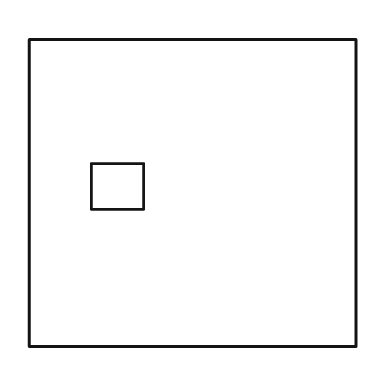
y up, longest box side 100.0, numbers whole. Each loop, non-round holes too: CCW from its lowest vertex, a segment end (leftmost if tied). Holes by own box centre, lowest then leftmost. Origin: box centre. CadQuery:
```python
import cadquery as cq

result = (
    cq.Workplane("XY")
    .moveTo(-50.0, -47.0)
    .lineTo(50.0, -47.0)
    .lineTo(50.0, 47.0)
    .lineTo(-50.0, 47.0)
    .close()
    .moveTo(-31.0, -5.0)
    .lineTo(-15.0, -5.0)
    .lineTo(-15.0, 9.0)
    .lineTo(-31.0, 9.0)
    .close()
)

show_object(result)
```